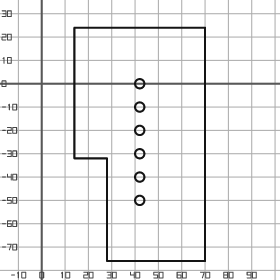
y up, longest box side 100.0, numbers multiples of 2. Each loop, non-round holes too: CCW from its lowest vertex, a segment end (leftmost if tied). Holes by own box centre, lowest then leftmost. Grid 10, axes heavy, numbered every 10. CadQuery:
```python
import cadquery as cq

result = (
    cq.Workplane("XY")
    .moveTo(28.0, -76.0)
    .lineTo(70.0, -76.0)
    .lineTo(70.0, 24.0)
    .lineTo(14.0, 24.0)
    .lineTo(14.0, -32.0)
    .lineTo(28.0, -32.0)
    .close()
    .moveTo(42.0, -50.0)
    .circle(2.0)
    .moveTo(42.0, -40.0)
    .circle(2.0)
    .moveTo(42.0, -30.0)
    .circle(2.0)
    .moveTo(42.0, -20.0)
    .circle(2.0)
    .moveTo(42.0, -10.0)
    .circle(2.0)
    .moveTo(42.0, 0.0)
    .circle(2.0)
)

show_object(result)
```